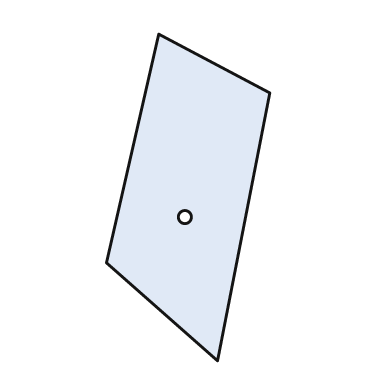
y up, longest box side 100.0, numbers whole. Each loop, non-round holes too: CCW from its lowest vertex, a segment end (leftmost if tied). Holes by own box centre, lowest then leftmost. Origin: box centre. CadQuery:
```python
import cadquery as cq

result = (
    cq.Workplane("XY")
    .moveTo(9.0, -50.0)
    .lineTo(25.0, 32.0)
    .lineTo(-9.0, 50.0)
    .lineTo(-25.0, -20.0)
    .close()
    .moveTo(-1.0, -6.0)
    .circle(2.0)
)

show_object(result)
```